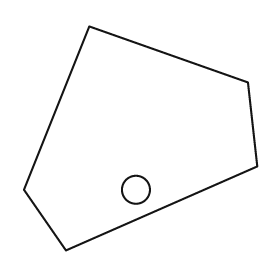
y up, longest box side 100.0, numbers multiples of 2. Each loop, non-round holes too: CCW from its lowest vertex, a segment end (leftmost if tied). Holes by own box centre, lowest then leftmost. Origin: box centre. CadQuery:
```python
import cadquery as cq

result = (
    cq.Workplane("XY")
    .moveTo(-32.0, -48.0)
    .lineTo(50.0, -12.0)
    .lineTo(46.0, 24.0)
    .lineTo(-22.0, 48.0)
    .lineTo(-50.0, -22.0)
    .close()
    .moveTo(-2.0, -22.0)
    .circle(6.0)
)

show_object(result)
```